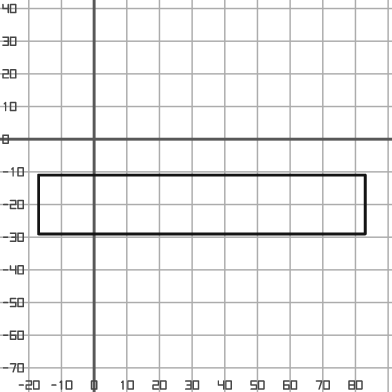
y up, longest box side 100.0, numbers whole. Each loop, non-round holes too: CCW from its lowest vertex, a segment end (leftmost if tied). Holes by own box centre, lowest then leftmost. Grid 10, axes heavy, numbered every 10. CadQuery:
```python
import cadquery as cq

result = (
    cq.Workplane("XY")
    .moveTo(-17.0, -29.0)
    .lineTo(83.0, -29.0)
    .lineTo(83.0, -11.0)
    .lineTo(-17.0, -11.0)
    .close()
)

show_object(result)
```